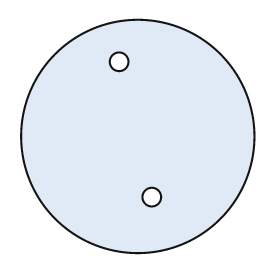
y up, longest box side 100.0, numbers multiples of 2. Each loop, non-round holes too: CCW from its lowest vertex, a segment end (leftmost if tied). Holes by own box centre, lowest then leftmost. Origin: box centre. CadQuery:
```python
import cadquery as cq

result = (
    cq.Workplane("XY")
    .moveTo(0.0, 0.0)
    .circle(50.0)
    .moveTo(6.0, -26.0)
    .circle(4.0)
    .moveTo(-8.0, 32.0)
    .circle(4.0)
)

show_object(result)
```